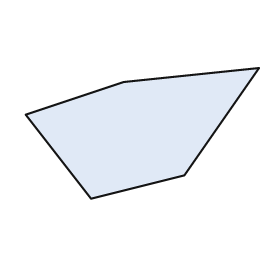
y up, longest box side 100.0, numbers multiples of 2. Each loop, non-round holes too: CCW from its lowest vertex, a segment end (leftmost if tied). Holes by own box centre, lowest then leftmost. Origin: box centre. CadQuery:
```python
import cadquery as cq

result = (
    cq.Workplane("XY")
    .moveTo(-22.0, -28.0)
    .lineTo(18.0, -18.0)
    .lineTo(50.0, 28.0)
    .lineTo(-8.0, 22.0)
    .lineTo(-50.0, 8.0)
    .close()
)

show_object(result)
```